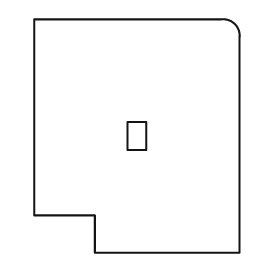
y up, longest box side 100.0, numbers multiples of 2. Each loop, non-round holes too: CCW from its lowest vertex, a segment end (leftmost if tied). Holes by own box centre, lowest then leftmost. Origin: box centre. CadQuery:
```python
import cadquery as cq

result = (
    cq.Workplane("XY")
    .moveTo(-18.0, -50.0)
    .lineTo(44.0, -50.0)
    .lineTo(44.0, 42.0)
    .threePointArc((42.0, 48.0), (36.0, 50.0))
    .lineTo(-44.0, 50.0)
    .lineTo(-44.0, -34.0)
    .lineTo(-18.0, -34.0)
    .close()
    .moveTo(-4.0, -6.0)
    .lineTo(4.0, -6.0)
    .lineTo(4.0, 6.0)
    .lineTo(-4.0, 6.0)
    .close()
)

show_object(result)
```